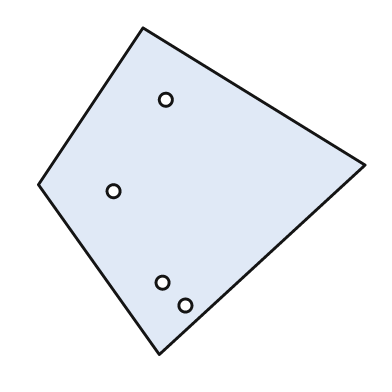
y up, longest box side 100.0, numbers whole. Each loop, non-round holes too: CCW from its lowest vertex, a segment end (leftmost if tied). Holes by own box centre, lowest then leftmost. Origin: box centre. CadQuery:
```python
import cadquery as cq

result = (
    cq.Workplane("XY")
    .moveTo(-13.0, -50.0)
    .lineTo(50.0, 8.0)
    .lineTo(-18.0, 50.0)
    .lineTo(-50.0, 2.0)
    .close()
    .moveTo(-5.0, -35.0)
    .circle(2.0)
    .moveTo(-12.0, -28.0)
    .circle(2.0)
    .moveTo(-27.0, 0.0)
    .circle(2.0)
    .moveTo(-11.0, 28.0)
    .circle(2.0)
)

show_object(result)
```